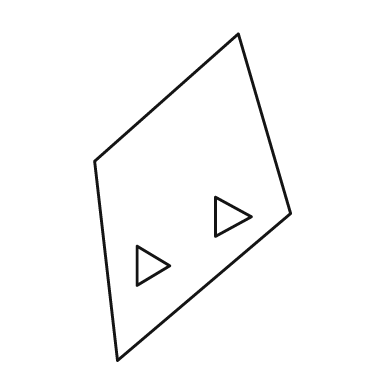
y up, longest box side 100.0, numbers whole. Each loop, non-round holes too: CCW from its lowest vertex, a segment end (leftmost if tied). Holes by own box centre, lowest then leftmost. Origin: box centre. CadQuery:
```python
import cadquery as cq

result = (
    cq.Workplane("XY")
    .moveTo(-23.0, -50.0)
    .lineTo(30.0, -5.0)
    .lineTo(14.0, 50.0)
    .lineTo(-30.0, 11.0)
    .close()
    .moveTo(-17.0, -27.0)
    .lineTo(-7.0, -21.0)
    .lineTo(-17.0, -15.0)
    .close()
    .moveTo(7.0, -12.0)
    .lineTo(18.0, -6.0)
    .lineTo(7.0, 0.0)
    .close()
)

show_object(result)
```